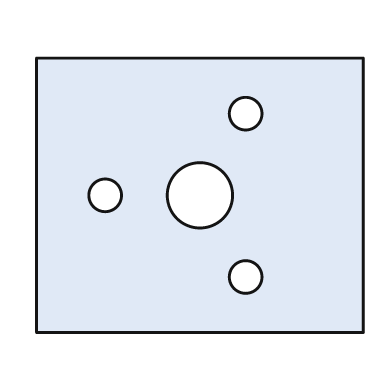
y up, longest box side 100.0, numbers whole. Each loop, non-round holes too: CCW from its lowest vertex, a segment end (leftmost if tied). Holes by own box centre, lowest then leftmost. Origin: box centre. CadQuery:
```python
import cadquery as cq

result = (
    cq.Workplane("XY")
    .moveTo(-50.0, -42.0)
    .lineTo(50.0, -42.0)
    .lineTo(50.0, 42.0)
    .lineTo(-50.0, 42.0)
    .close()
    .moveTo(14.0, -25.0)
    .circle(5.0)
    .moveTo(-29.0, 0.0)
    .circle(5.0)
    .moveTo(0.0, 0.0)
    .circle(10.0)
    .moveTo(14.0, 25.0)
    .circle(5.0)
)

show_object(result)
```